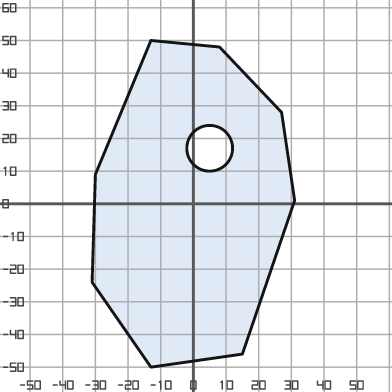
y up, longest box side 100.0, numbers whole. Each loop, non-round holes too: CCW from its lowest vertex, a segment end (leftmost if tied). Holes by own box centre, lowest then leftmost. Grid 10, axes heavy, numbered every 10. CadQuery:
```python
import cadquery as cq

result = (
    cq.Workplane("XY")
    .moveTo(-13.0, -50.0)
    .lineTo(15.0, -46.0)
    .lineTo(31.0, 1.0)
    .lineTo(27.0, 28.0)
    .lineTo(8.0, 48.0)
    .lineTo(-13.0, 50.0)
    .lineTo(-30.0, 9.0)
    .lineTo(-31.0, -24.0)
    .close()
    .moveTo(5.0, 17.0)
    .circle(7.0)
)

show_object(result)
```